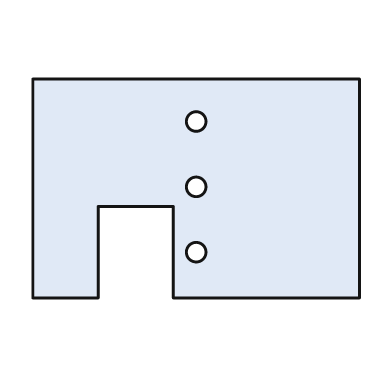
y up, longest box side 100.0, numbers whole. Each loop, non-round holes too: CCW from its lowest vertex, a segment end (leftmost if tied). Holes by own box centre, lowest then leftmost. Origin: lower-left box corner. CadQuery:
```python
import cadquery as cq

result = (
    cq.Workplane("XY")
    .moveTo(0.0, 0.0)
    .lineTo(20.0, 0.0)
    .lineTo(20.0, 28.0)
    .lineTo(43.0, 28.0)
    .lineTo(43.0, 0.0)
    .lineTo(100.0, 0.0)
    .lineTo(100.0, 67.0)
    .lineTo(0.0, 67.0)
    .close()
    .moveTo(50.0, 14.0)
    .circle(3.0)
    .moveTo(50.0, 34.0)
    .circle(3.0)
    .moveTo(50.0, 54.0)
    .circle(3.0)
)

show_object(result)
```